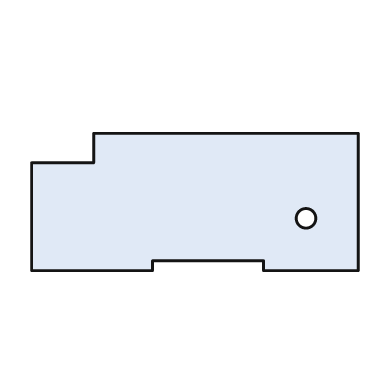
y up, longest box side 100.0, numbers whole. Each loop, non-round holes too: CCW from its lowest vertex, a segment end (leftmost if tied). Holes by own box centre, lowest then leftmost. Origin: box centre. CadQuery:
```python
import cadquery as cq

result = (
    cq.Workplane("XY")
    .moveTo(-50.0, -21.0)
    .lineTo(-13.0, -21.0)
    .lineTo(-13.0, -18.0)
    .lineTo(21.0, -18.0)
    .lineTo(21.0, -21.0)
    .lineTo(50.0, -21.0)
    .lineTo(50.0, 21.0)
    .lineTo(-31.0, 21.0)
    .lineTo(-31.0, 12.0)
    .lineTo(-50.0, 12.0)
    .close()
    .moveTo(34.0, -5.0)
    .circle(3.0)
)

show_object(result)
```